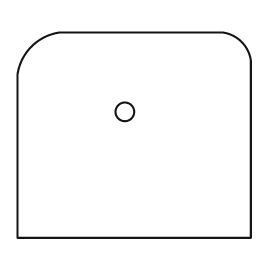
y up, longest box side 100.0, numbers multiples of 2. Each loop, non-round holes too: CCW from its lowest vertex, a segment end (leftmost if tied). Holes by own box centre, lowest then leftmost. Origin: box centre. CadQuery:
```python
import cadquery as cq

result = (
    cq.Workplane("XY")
    .moveTo(-50.0, -44.0)
    .lineTo(50.0, -44.0)
    .lineTo(50.0, 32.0)
    .threePointArc((46.0, 40.0), (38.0, 44.0))
    .lineTo(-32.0, 44.0)
    .threePointArc((-44.0, 38.0), (-50.0, 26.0))
    .close()
    .moveTo(-4.0, 10.0)
    .circle(4.0)
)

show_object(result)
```